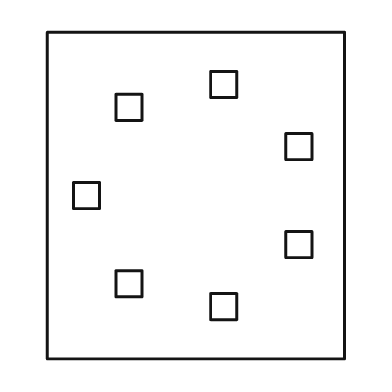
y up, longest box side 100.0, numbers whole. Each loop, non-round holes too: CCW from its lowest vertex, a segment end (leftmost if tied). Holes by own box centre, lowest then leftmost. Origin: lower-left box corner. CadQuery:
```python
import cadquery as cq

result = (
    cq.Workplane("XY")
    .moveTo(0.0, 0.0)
    .lineTo(91.0, 0.0)
    .lineTo(91.0, 100.0)
    .lineTo(0.0, 100.0)
    .close()
    .moveTo(50.0, 12.0)
    .lineTo(58.0, 12.0)
    .lineTo(58.0, 20.0)
    .lineTo(50.0, 20.0)
    .close()
    .moveTo(21.0, 19.0)
    .lineTo(29.0, 19.0)
    .lineTo(29.0, 27.0)
    .lineTo(21.0, 27.0)
    .close()
    .moveTo(73.0, 31.0)
    .lineTo(81.0, 31.0)
    .lineTo(81.0, 39.0)
    .lineTo(73.0, 39.0)
    .close()
    .moveTo(8.0, 46.0)
    .lineTo(16.0, 46.0)
    .lineTo(16.0, 54.0)
    .lineTo(8.0, 54.0)
    .close()
    .moveTo(73.0, 61.0)
    .lineTo(81.0, 61.0)
    .lineTo(81.0, 69.0)
    .lineTo(73.0, 69.0)
    .close()
    .moveTo(21.0, 73.0)
    .lineTo(29.0, 73.0)
    .lineTo(29.0, 81.0)
    .lineTo(21.0, 81.0)
    .close()
    .moveTo(50.0, 80.0)
    .lineTo(58.0, 80.0)
    .lineTo(58.0, 88.0)
    .lineTo(50.0, 88.0)
    .close()
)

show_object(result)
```